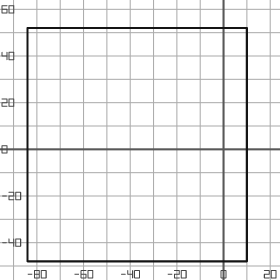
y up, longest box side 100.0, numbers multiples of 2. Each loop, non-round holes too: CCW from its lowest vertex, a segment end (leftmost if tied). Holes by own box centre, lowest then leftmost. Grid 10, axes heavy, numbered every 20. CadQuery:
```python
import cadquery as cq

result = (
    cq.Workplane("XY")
    .moveTo(-84.0, -48.0)
    .lineTo(10.0, -48.0)
    .lineTo(10.0, 52.0)
    .lineTo(-84.0, 52.0)
    .close()
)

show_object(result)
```